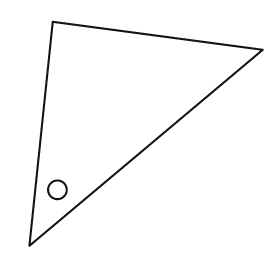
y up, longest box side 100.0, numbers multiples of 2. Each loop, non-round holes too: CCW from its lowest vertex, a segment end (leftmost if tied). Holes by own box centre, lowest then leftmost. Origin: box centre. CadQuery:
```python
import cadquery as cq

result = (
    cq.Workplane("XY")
    .moveTo(-50.0, -48.0)
    .lineTo(50.0, 36.0)
    .lineTo(-40.0, 48.0)
    .close()
    .moveTo(-38.0, -24.0)
    .circle(4.0)
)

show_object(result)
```